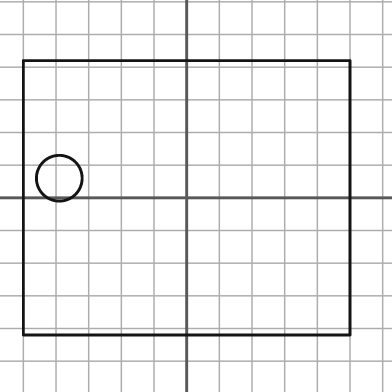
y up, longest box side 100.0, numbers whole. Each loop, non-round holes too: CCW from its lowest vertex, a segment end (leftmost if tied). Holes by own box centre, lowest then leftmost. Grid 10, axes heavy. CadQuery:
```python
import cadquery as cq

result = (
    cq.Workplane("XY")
    .moveTo(-50.0, -42.0)
    .lineTo(50.0, -42.0)
    .lineTo(50.0, 42.0)
    .lineTo(-50.0, 42.0)
    .close()
    .moveTo(-39.0, 6.0)
    .circle(7.0)
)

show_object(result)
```